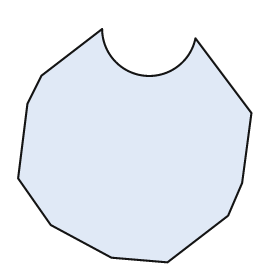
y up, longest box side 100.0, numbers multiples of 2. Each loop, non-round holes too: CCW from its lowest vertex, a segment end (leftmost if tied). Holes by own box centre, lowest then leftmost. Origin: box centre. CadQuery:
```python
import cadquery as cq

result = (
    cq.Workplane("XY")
    .moveTo(14.0, -50.0)
    .lineTo(40.0, -30.0)
    .lineTo(46.0, -16.0)
    .lineTo(50.0, 14.0)
    .lineTo(26.0, 46.0)
    .threePointArc((4.0, 30.0), (-14.0, 50.0))
    .lineTo(-40.0, 30.0)
    .lineTo(-46.0, 18.0)
    .lineTo(-50.0, -14.0)
    .lineTo(-36.0, -34.0)
    .lineTo(-10.0, -48.0)
    .close()
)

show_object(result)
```